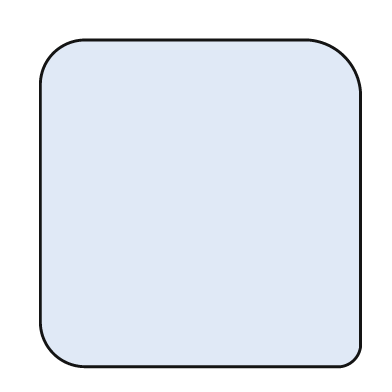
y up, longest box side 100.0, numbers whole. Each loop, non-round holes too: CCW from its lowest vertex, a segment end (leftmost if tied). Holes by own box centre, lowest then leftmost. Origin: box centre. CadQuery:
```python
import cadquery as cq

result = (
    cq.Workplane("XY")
    .moveTo(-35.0, -50.0)
    .lineTo(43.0, -50.0)
    .threePointArc((47.0, -48.0), (49.0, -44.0))
    .lineTo(49.0, 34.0)
    .threePointArc((44.0, 45.0), (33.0, 50.0))
    .lineTo(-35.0, 50.0)
    .threePointArc((-45.0, 46.0), (-49.0, 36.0))
    .lineTo(-49.0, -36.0)
    .threePointArc((-45.0, -46.0), (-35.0, -50.0))
    .close()
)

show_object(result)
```